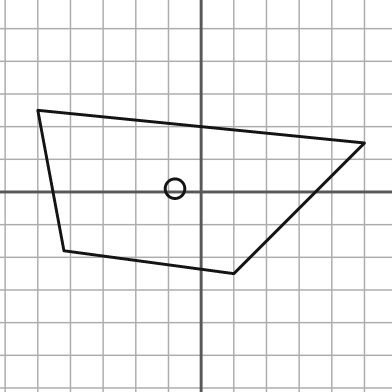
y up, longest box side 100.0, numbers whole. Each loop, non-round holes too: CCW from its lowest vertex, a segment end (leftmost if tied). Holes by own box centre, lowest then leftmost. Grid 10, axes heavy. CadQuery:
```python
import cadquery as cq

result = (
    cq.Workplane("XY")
    .moveTo(10.0, -25.0)
    .lineTo(50.0, 15.0)
    .lineTo(-50.0, 25.0)
    .lineTo(-42.0, -18.0)
    .close()
    .moveTo(-8.0, 1.0)
    .circle(3.0)
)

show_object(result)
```